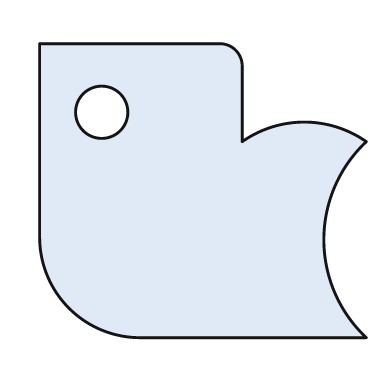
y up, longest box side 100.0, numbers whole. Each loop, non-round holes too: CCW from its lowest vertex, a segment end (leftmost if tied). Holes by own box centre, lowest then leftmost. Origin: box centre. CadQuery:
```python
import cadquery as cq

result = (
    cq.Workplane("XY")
    .moveTo(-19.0, -45.0)
    .lineTo(50.0, -45.0)
    .threePointArc((37.0, -15.0), (50.0, 15.0))
    .threePointArc((31.0, 21.0), (12.0, 15.0))
    .lineTo(12.0, 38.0)
    .threePointArc((10.0, 43.0), (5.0, 45.0))
    .lineTo(-50.0, 45.0)
    .lineTo(-50.0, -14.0)
    .threePointArc((-41.0, -36.0), (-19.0, -45.0))
    .close()
    .moveTo(-31.0, 24.0)
    .circle(8.0)
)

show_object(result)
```